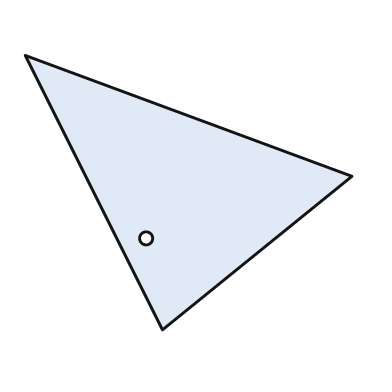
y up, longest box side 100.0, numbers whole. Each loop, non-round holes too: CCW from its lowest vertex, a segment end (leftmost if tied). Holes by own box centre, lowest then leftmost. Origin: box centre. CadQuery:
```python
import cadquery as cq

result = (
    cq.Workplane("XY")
    .moveTo(-8.0, -42.0)
    .lineTo(50.0, 5.0)
    .lineTo(-50.0, 42.0)
    .close()
    .moveTo(-13.0, -14.0)
    .circle(2.0)
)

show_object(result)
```